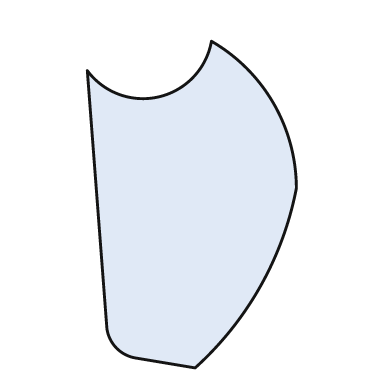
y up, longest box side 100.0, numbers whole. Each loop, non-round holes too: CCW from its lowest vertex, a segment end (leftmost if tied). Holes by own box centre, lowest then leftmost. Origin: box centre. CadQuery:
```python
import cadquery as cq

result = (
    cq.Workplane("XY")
    .moveTo(1.0, -50.0)
    .threePointArc((21.0, -25.0), (32.0, 5.0))
    .threePointArc((25.0, 31.0), (6.0, 50.0))
    .threePointArc((-10.0, 33.0), (-32.0, 41.0))
    .lineTo(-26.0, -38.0)
    .threePointArc((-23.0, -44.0), (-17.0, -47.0))
    .close()
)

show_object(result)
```